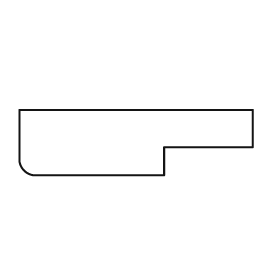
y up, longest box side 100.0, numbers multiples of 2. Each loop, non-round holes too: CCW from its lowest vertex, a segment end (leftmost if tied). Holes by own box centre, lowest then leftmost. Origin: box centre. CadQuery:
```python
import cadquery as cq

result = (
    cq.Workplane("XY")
    .moveTo(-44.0, -14.0)
    .lineTo(12.0, -14.0)
    .lineTo(12.0, -2.0)
    .lineTo(50.0, -2.0)
    .lineTo(50.0, 14.0)
    .lineTo(-50.0, 14.0)
    .lineTo(-50.0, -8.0)
    .threePointArc((-48.0, -12.0), (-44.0, -14.0))
    .close()
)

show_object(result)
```